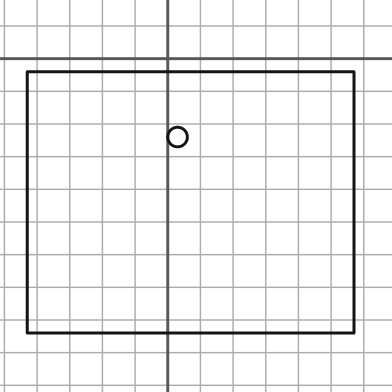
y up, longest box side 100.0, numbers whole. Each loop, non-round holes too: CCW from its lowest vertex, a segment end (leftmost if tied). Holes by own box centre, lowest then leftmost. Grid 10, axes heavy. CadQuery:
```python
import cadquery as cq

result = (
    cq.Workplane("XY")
    .moveTo(-43.0, -84.0)
    .lineTo(57.0, -84.0)
    .lineTo(57.0, -4.0)
    .lineTo(-43.0, -4.0)
    .close()
    .moveTo(3.0, -24.0)
    .circle(3.0)
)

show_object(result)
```